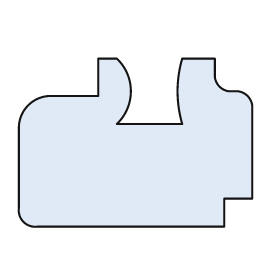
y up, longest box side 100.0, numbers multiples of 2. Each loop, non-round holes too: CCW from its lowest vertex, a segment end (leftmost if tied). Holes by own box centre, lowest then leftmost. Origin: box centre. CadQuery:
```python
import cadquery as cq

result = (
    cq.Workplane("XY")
    .moveTo(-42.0, -36.0)
    .lineTo(38.0, -36.0)
    .lineTo(38.0, -24.0)
    .lineTo(50.0, -24.0)
    .lineTo(50.0, 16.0)
    .threePointArc((48.0, 20.0), (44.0, 22.0))
    .lineTo(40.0, 22.0)
    .threePointArc((36.0, 24.0), (34.0, 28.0))
    .lineTo(34.0, 36.0)
    .lineTo(20.0, 36.0)
    .threePointArc((18.0, 22.0), (20.0, 8.0))
    .lineTo(-8.0, 8.0)
    .threePointArc((-2.0, 22.0), (-8.0, 36.0))
    .lineTo(-16.0, 36.0)
    .lineTo(-16.0, 20.0)
    .lineTo(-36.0, 20.0)
    .threePointArc((-46.0, 16.0), (-50.0, 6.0))
    .lineTo(-50.0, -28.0)
    .threePointArc((-48.0, -34.0), (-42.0, -36.0))
    .close()
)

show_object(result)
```